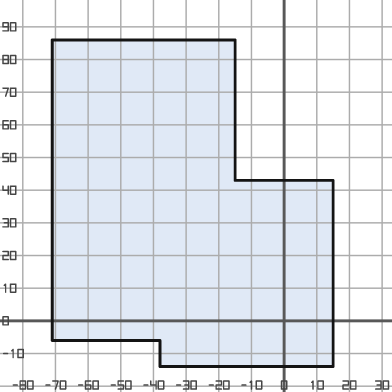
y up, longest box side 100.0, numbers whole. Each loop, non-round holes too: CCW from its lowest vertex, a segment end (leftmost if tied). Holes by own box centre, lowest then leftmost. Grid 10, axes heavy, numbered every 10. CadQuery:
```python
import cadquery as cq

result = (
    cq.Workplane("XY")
    .moveTo(-38.0, -14.0)
    .lineTo(15.0, -14.0)
    .lineTo(15.0, 43.0)
    .lineTo(-15.0, 43.0)
    .lineTo(-15.0, 86.0)
    .lineTo(-71.0, 86.0)
    .lineTo(-71.0, -6.0)
    .lineTo(-38.0, -6.0)
    .close()
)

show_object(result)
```